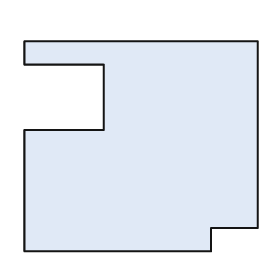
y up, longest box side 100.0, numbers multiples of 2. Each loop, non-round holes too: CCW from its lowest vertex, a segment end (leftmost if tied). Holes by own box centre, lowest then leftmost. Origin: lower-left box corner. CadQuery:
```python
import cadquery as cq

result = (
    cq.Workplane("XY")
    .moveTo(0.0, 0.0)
    .lineTo(80.0, 0.0)
    .lineTo(80.0, 10.0)
    .lineTo(100.0, 10.0)
    .lineTo(100.0, 90.0)
    .lineTo(0.0, 90.0)
    .lineTo(0.0, 80.0)
    .lineTo(34.0, 80.0)
    .lineTo(34.0, 52.0)
    .lineTo(0.0, 52.0)
    .close()
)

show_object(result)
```